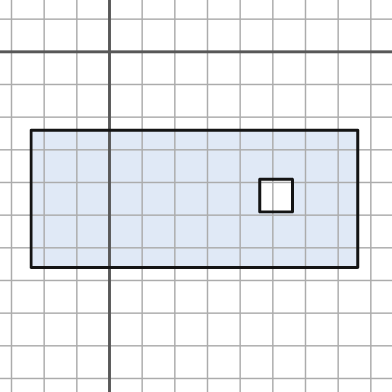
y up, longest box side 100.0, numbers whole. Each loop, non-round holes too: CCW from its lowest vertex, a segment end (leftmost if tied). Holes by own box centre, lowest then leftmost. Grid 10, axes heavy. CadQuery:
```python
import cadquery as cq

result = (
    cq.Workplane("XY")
    .moveTo(-24.0, -66.0)
    .lineTo(76.0, -66.0)
    .lineTo(76.0, -24.0)
    .lineTo(-24.0, -24.0)
    .close()
    .moveTo(46.0, -49.0)
    .lineTo(56.0, -49.0)
    .lineTo(56.0, -39.0)
    .lineTo(46.0, -39.0)
    .close()
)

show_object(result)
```